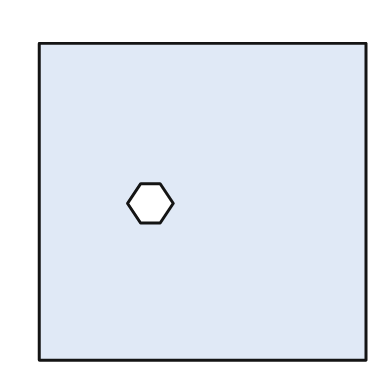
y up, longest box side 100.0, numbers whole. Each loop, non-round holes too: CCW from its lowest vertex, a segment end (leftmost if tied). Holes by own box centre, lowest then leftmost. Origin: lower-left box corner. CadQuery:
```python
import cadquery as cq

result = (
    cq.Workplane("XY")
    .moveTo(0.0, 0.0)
    .lineTo(100.0, 0.0)
    .lineTo(100.0, 97.0)
    .lineTo(0.0, 97.0)
    .close()
    .moveTo(31.0, 42.0)
    .lineTo(37.0, 42.0)
    .lineTo(41.0, 48.0)
    .lineTo(37.0, 54.0)
    .lineTo(31.0, 54.0)
    .lineTo(27.0, 48.0)
    .close()
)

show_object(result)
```